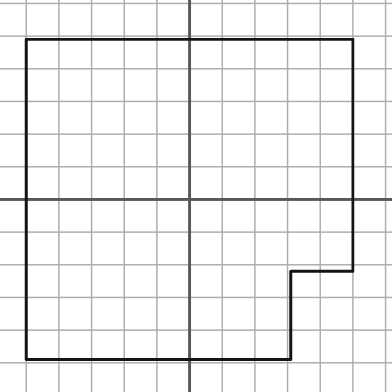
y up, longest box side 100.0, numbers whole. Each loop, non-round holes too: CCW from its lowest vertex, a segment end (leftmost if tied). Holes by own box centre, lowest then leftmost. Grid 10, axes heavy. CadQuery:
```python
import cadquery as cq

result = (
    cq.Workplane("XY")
    .moveTo(-50.0, -49.0)
    .lineTo(31.0, -49.0)
    .lineTo(31.0, -22.0)
    .lineTo(50.0, -22.0)
    .lineTo(50.0, 49.0)
    .lineTo(-50.0, 49.0)
    .close()
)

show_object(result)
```